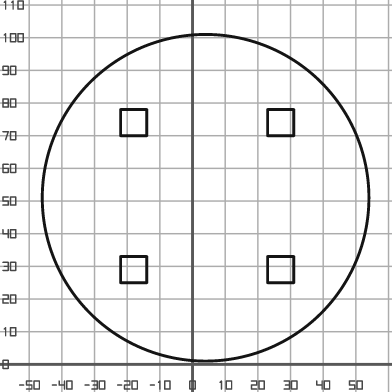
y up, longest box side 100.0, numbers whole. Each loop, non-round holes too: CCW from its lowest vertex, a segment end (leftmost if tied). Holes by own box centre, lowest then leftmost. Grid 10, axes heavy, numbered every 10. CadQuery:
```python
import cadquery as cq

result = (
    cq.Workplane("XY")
    .moveTo(4.0, 51.0)
    .circle(50.0)
    .moveTo(-22.0, 25.0)
    .lineTo(-14.0, 25.0)
    .lineTo(-14.0, 33.0)
    .lineTo(-22.0, 33.0)
    .close()
    .moveTo(23.0, 25.0)
    .lineTo(31.0, 25.0)
    .lineTo(31.0, 33.0)
    .lineTo(23.0, 33.0)
    .close()
    .moveTo(-22.0, 70.0)
    .lineTo(-14.0, 70.0)
    .lineTo(-14.0, 78.0)
    .lineTo(-22.0, 78.0)
    .close()
    .moveTo(23.0, 70.0)
    .lineTo(31.0, 70.0)
    .lineTo(31.0, 78.0)
    .lineTo(23.0, 78.0)
    .close()
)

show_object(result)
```